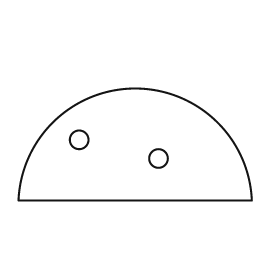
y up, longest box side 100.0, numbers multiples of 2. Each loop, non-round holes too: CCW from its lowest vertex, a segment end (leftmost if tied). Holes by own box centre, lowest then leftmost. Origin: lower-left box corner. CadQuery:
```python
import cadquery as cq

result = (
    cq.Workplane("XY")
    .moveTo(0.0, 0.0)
    .lineTo(100.0, 0.0)
    .threePointArc((50.0, 48.0), (0.0, 0.0))
    .close()
    .moveTo(60.0, 18.0)
    .circle(4.0)
    .moveTo(26.0, 26.0)
    .circle(4.0)
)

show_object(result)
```